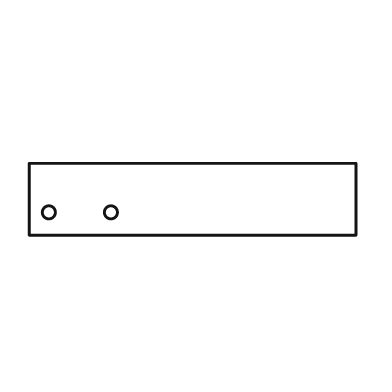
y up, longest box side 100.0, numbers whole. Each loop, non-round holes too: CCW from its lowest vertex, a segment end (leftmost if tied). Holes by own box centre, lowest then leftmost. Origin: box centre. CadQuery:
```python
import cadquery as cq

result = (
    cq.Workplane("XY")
    .moveTo(-50.0, -11.0)
    .lineTo(50.0, -11.0)
    .lineTo(50.0, 11.0)
    .lineTo(-50.0, 11.0)
    .close()
    .moveTo(-44.0, -4.0)
    .circle(2.0)
    .moveTo(-25.0, -4.0)
    .circle(2.0)
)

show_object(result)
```